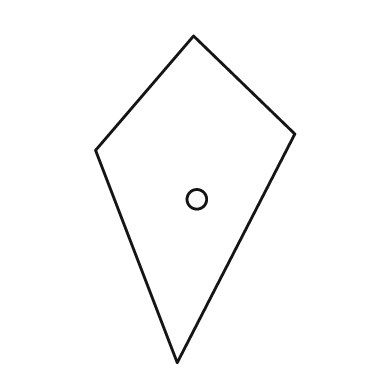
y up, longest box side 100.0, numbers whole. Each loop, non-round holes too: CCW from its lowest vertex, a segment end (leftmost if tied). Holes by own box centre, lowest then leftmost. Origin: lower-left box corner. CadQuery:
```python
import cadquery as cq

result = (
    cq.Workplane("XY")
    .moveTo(25.0, 0.0)
    .lineTo(61.0, 70.0)
    .lineTo(30.0, 100.0)
    .lineTo(0.0, 65.0)
    .close()
    .moveTo(31.0, 50.0)
    .circle(3.0)
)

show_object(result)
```